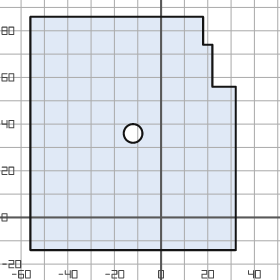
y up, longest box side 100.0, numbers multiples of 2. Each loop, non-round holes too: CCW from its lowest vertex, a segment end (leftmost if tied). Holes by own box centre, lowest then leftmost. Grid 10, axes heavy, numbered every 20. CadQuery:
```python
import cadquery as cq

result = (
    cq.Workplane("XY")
    .moveTo(-56.0, -14.0)
    .lineTo(32.0, -14.0)
    .lineTo(32.0, 56.0)
    .lineTo(22.0, 56.0)
    .lineTo(22.0, 74.0)
    .lineTo(18.0, 74.0)
    .lineTo(18.0, 86.0)
    .lineTo(-56.0, 86.0)
    .close()
    .moveTo(-12.0, 36.0)
    .circle(4.0)
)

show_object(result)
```